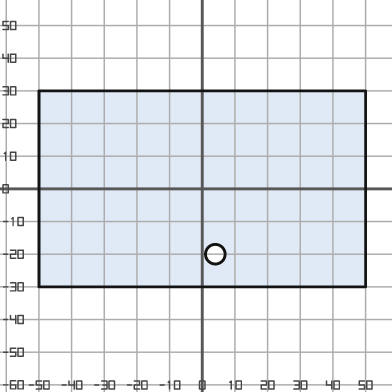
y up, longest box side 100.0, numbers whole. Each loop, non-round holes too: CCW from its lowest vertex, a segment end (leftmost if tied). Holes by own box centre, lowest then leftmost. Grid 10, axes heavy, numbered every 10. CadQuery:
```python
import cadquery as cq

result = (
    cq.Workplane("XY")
    .moveTo(-50.0, -30.0)
    .lineTo(50.0, -30.0)
    .lineTo(50.0, 30.0)
    .lineTo(-50.0, 30.0)
    .close()
    .moveTo(4.0, -20.0)
    .circle(3.0)
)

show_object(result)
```